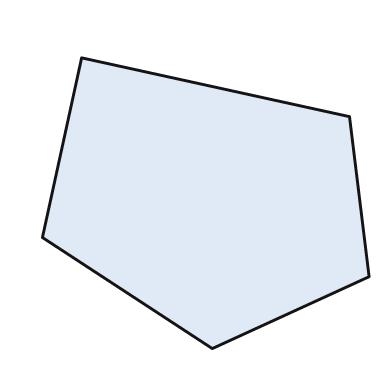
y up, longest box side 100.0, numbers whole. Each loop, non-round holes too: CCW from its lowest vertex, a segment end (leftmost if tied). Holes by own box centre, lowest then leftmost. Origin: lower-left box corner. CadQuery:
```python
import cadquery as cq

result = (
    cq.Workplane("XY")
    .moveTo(52.0, 0.0)
    .lineTo(100.0, 22.0)
    .lineTo(94.0, 71.0)
    .lineTo(12.0, 89.0)
    .lineTo(0.0, 34.0)
    .close()
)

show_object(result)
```